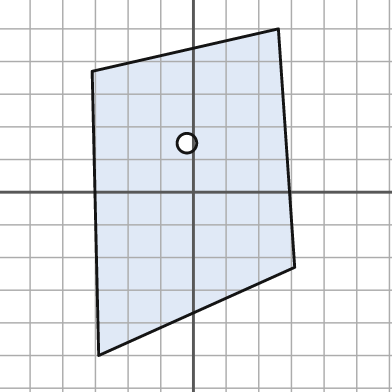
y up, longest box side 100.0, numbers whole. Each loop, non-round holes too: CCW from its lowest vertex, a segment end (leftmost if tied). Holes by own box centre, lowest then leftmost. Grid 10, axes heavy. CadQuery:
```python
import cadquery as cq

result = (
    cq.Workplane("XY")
    .moveTo(-29.0, -50.0)
    .lineTo(31.0, -23.0)
    .lineTo(26.0, 50.0)
    .lineTo(-31.0, 37.0)
    .close()
    .moveTo(-2.0, 15.0)
    .circle(3.0)
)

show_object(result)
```